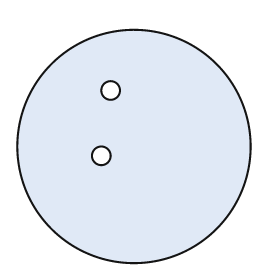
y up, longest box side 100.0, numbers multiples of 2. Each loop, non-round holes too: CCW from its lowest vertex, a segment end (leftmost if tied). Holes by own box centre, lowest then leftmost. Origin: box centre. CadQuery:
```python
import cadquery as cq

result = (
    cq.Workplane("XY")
    .moveTo(0.0, 0.0)
    .circle(50.0)
    .moveTo(-14.0, -4.0)
    .circle(4.0)
    .moveTo(-10.0, 24.0)
    .circle(4.0)
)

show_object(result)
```